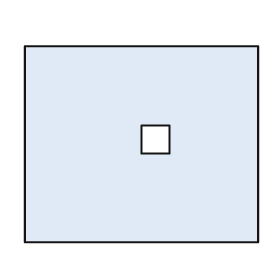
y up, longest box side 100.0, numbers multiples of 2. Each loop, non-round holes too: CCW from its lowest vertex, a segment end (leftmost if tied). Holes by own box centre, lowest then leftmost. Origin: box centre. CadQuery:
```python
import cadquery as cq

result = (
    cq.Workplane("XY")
    .moveTo(-50.0, -42.0)
    .lineTo(50.0, -42.0)
    .lineTo(50.0, 42.0)
    .lineTo(-50.0, 42.0)
    .close()
    .moveTo(0.0, -4.0)
    .lineTo(12.0, -4.0)
    .lineTo(12.0, 8.0)
    .lineTo(0.0, 8.0)
    .close()
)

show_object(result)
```